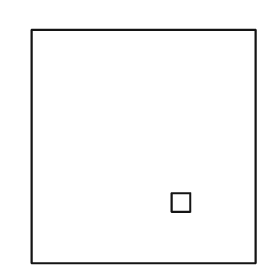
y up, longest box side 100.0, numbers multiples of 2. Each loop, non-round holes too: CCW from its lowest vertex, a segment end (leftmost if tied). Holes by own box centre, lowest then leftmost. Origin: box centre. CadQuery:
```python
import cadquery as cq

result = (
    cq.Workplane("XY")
    .moveTo(-48.0, -50.0)
    .lineTo(48.0, -50.0)
    .lineTo(48.0, 50.0)
    .lineTo(-48.0, 50.0)
    .close()
    .moveTo(12.0, -28.0)
    .lineTo(20.0, -28.0)
    .lineTo(20.0, -20.0)
    .lineTo(12.0, -20.0)
    .close()
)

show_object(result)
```